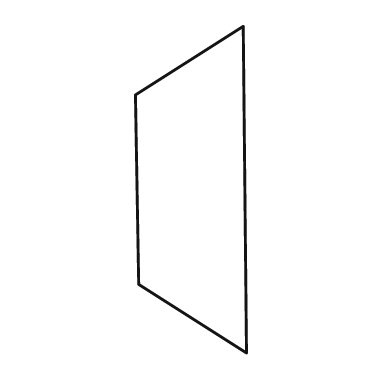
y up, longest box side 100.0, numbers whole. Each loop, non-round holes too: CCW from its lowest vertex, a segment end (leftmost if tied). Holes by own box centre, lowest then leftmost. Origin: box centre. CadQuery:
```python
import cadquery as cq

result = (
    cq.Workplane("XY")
    .moveTo(17.0, -50.0)
    .lineTo(16.0, 50.0)
    .lineTo(-17.0, 29.0)
    .lineTo(-16.0, -29.0)
    .close()
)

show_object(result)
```